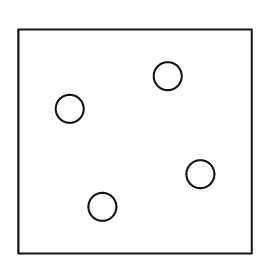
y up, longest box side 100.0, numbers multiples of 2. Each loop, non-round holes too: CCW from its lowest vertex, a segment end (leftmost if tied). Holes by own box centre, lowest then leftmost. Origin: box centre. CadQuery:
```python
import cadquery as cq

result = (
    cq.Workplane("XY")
    .moveTo(-50.0, -48.0)
    .lineTo(50.0, -48.0)
    .lineTo(50.0, 48.0)
    .lineTo(-50.0, 48.0)
    .close()
    .moveTo(-14.0, -28.0)
    .circle(6.0)
    .moveTo(28.0, -14.0)
    .circle(6.0)
    .moveTo(-28.0, 14.0)
    .circle(6.0)
    .moveTo(14.0, 28.0)
    .circle(6.0)
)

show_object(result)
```